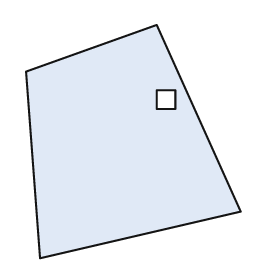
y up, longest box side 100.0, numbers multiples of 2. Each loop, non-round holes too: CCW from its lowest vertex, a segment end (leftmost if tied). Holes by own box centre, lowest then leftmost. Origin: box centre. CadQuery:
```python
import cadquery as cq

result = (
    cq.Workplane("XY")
    .moveTo(-40.0, -50.0)
    .lineTo(46.0, -30.0)
    .lineTo(10.0, 50.0)
    .lineTo(-46.0, 30.0)
    .close()
    .moveTo(10.0, 14.0)
    .lineTo(18.0, 14.0)
    .lineTo(18.0, 22.0)
    .lineTo(10.0, 22.0)
    .close()
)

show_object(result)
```